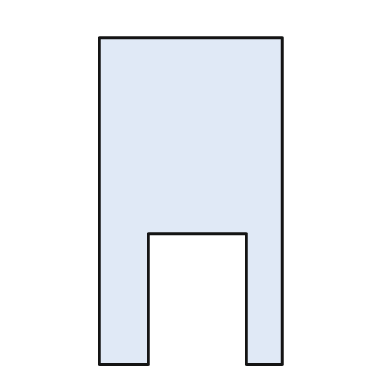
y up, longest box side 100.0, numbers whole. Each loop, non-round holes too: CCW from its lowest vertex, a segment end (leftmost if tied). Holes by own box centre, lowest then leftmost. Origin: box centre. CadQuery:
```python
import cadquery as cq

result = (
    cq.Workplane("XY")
    .moveTo(-28.0, -50.0)
    .lineTo(-13.0, -50.0)
    .lineTo(-13.0, -10.0)
    .lineTo(17.0, -10.0)
    .lineTo(17.0, -50.0)
    .lineTo(28.0, -50.0)
    .lineTo(28.0, 50.0)
    .lineTo(-28.0, 50.0)
    .close()
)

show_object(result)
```